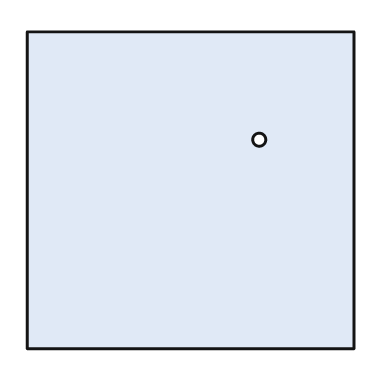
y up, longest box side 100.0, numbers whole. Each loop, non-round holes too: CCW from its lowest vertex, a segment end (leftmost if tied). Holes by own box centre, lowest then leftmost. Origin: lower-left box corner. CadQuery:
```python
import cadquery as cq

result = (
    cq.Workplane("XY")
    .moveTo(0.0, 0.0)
    .lineTo(100.0, 0.0)
    .lineTo(100.0, 97.0)
    .lineTo(0.0, 97.0)
    .close()
    .moveTo(71.0, 64.0)
    .circle(2.0)
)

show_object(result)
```